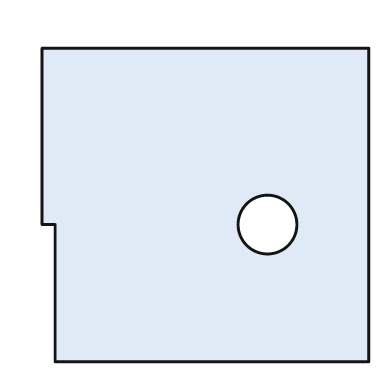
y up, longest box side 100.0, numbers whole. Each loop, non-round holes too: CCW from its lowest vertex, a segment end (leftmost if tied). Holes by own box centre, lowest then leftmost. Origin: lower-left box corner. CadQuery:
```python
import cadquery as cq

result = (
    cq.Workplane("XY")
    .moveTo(4.0, 0.0)
    .lineTo(100.0, 0.0)
    .lineTo(100.0, 96.0)
    .lineTo(0.0, 96.0)
    .lineTo(0.0, 42.0)
    .lineTo(4.0, 42.0)
    .close()
    .moveTo(69.0, 42.0)
    .circle(9.0)
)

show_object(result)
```